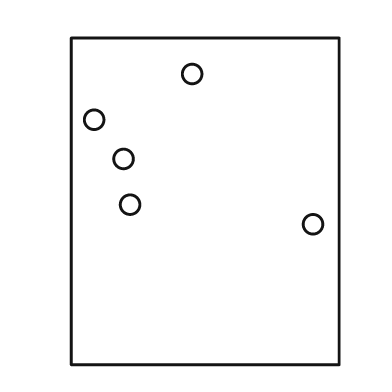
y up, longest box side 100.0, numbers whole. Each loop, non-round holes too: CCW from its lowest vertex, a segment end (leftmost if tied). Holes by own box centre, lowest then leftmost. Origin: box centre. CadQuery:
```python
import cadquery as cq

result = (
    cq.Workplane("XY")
    .moveTo(-41.0, -50.0)
    .lineTo(41.0, -50.0)
    .lineTo(41.0, 50.0)
    .lineTo(-41.0, 50.0)
    .close()
    .moveTo(33.0, -7.0)
    .circle(3.0)
    .moveTo(-23.0, -1.0)
    .circle(3.0)
    .moveTo(-25.0, 13.0)
    .circle(3.0)
    .moveTo(-34.0, 25.0)
    .circle(3.0)
    .moveTo(-4.0, 39.0)
    .circle(3.0)
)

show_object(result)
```